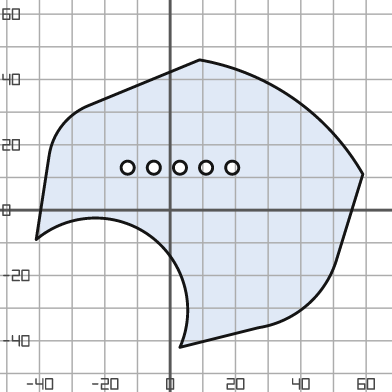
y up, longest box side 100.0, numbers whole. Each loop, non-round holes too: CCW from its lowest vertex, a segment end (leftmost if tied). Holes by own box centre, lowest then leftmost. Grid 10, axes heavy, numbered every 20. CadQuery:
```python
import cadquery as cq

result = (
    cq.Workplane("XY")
    .moveTo(3.0, -42.0)
    .lineTo(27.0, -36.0)
    .threePointArc((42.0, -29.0), (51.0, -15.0))
    .lineTo(59.0, 11.0)
    .threePointArc((38.0, 34.0), (9.0, 46.0))
    .lineTo(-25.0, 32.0)
    .threePointArc((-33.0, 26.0), (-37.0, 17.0))
    .lineTo(-41.0, -9.0)
    .threePointArc((-6.0, -8.0), (3.0, -42.0))
    .close()
    .moveTo(-13.0, 13.0)
    .circle(2.0)
    .moveTo(-5.0, 13.0)
    .circle(2.0)
    .moveTo(3.0, 13.0)
    .circle(2.0)
    .moveTo(11.0, 13.0)
    .circle(2.0)
    .moveTo(19.0, 13.0)
    .circle(2.0)
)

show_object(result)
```